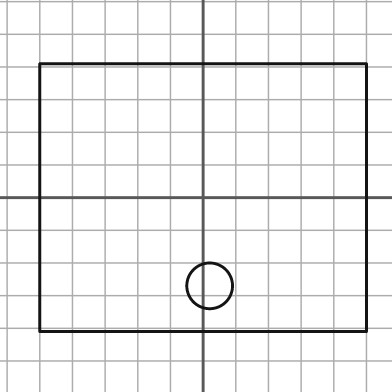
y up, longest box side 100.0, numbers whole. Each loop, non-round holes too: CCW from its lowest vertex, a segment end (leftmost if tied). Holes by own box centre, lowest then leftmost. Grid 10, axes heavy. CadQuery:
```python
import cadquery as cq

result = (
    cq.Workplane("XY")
    .moveTo(-50.0, -41.0)
    .lineTo(50.0, -41.0)
    .lineTo(50.0, 41.0)
    .lineTo(-50.0, 41.0)
    .close()
    .moveTo(2.0, -27.0)
    .circle(7.0)
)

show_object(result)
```